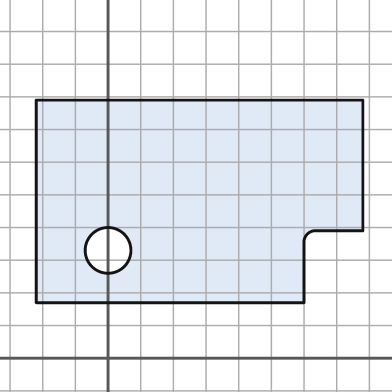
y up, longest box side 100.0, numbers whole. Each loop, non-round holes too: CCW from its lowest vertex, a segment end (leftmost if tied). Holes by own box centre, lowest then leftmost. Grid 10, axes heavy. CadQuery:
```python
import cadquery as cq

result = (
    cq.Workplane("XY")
    .moveTo(-22.0, 17.0)
    .lineTo(60.0, 17.0)
    .lineTo(60.0, 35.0)
    .threePointArc((61.0, 38.0), (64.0, 39.0))
    .lineTo(78.0, 39.0)
    .lineTo(78.0, 79.0)
    .lineTo(-22.0, 79.0)
    .close()
    .moveTo(0.0, 33.0)
    .circle(7.0)
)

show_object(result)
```